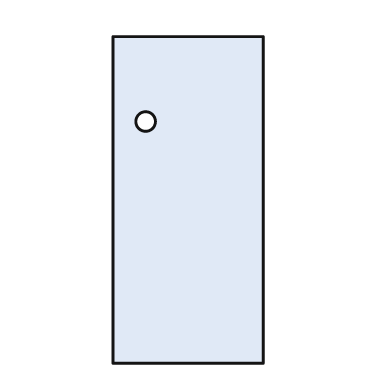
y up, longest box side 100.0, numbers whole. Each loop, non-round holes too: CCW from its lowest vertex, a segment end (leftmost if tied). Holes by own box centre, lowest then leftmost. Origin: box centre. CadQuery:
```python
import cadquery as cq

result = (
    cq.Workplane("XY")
    .moveTo(-23.0, -50.0)
    .lineTo(23.0, -50.0)
    .lineTo(23.0, 50.0)
    .lineTo(-23.0, 50.0)
    .close()
    .moveTo(-13.0, 24.0)
    .circle(3.0)
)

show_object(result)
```